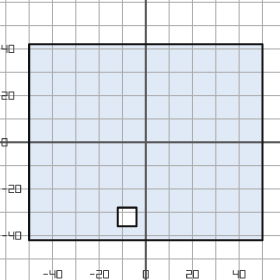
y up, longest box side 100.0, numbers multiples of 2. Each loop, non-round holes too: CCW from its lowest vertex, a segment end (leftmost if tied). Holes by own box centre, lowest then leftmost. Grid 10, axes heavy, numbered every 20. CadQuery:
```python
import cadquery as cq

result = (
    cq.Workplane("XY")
    .moveTo(-50.0, -42.0)
    .lineTo(50.0, -42.0)
    .lineTo(50.0, 42.0)
    .lineTo(-50.0, 42.0)
    .close()
    .moveTo(-12.0, -36.0)
    .lineTo(-4.0, -36.0)
    .lineTo(-4.0, -28.0)
    .lineTo(-12.0, -28.0)
    .close()
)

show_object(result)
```